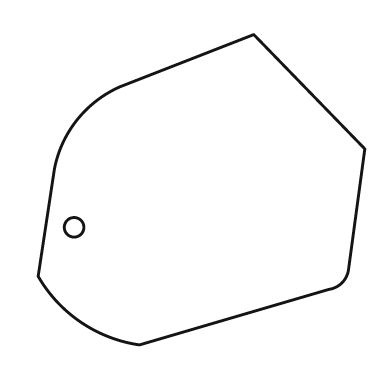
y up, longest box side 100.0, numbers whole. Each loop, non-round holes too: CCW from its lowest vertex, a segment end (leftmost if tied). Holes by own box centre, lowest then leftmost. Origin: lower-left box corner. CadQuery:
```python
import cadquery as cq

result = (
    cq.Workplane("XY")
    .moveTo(31.0, 0.0)
    .lineTo(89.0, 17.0)
    .threePointArc((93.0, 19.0), (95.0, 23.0))
    .lineTo(100.0, 60.0)
    .lineTo(66.0, 95.0)
    .lineTo(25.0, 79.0)
    .threePointArc((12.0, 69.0), (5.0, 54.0))
    .lineTo(0.0, 21.0)
    .threePointArc((13.0, 7.0), (31.0, 0.0))
    .close()
    .moveTo(11.0, 36.0)
    .circle(3.0)
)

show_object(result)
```